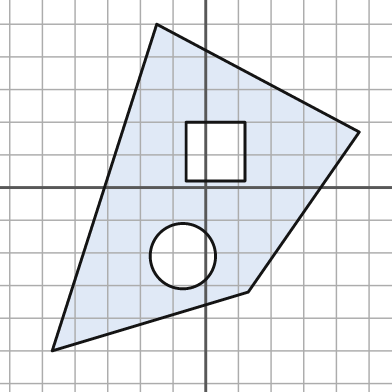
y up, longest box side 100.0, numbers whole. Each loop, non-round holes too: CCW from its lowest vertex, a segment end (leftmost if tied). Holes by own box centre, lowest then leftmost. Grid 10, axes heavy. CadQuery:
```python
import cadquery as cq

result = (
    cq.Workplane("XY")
    .moveTo(-47.0, -50.0)
    .lineTo(13.0, -32.0)
    .lineTo(47.0, 17.0)
    .lineTo(-15.0, 50.0)
    .close()
    .moveTo(-7.0, -21.0)
    .circle(10.0)
    .moveTo(-6.0, 2.0)
    .lineTo(12.0, 2.0)
    .lineTo(12.0, 20.0)
    .lineTo(-6.0, 20.0)
    .close()
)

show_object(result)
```